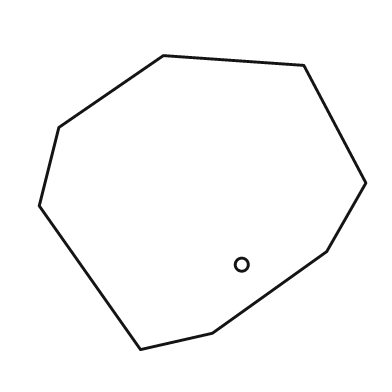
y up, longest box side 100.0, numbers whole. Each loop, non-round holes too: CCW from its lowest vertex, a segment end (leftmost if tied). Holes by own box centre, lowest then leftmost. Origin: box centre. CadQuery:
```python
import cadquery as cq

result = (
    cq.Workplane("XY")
    .moveTo(-19.0, -45.0)
    .lineTo(3.0, -40.0)
    .lineTo(38.0, -15.0)
    .lineTo(50.0, 6.0)
    .lineTo(31.0, 42.0)
    .lineTo(-12.0, 45.0)
    .lineTo(-44.0, 23.0)
    .lineTo(-50.0, -1.0)
    .close()
    .moveTo(12.0, -19.0)
    .circle(2.0)
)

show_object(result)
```